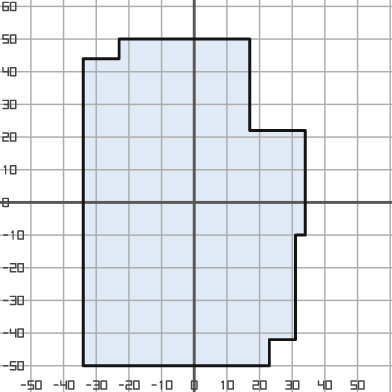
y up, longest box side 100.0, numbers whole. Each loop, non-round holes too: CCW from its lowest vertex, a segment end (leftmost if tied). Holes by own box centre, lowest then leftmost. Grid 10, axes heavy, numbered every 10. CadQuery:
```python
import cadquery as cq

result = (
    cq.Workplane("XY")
    .moveTo(-34.0, -50.0)
    .lineTo(23.0, -50.0)
    .lineTo(23.0, -42.0)
    .lineTo(31.0, -42.0)
    .lineTo(31.0, -10.0)
    .lineTo(34.0, -10.0)
    .lineTo(34.0, 22.0)
    .lineTo(17.0, 22.0)
    .lineTo(17.0, 50.0)
    .lineTo(-23.0, 50.0)
    .lineTo(-23.0, 44.0)
    .lineTo(-34.0, 44.0)
    .close()
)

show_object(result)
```